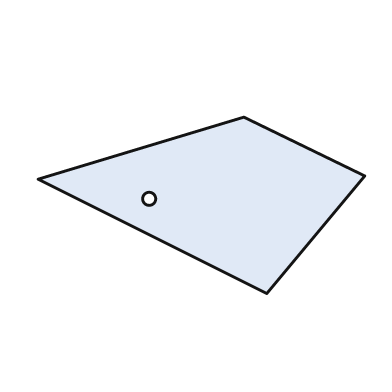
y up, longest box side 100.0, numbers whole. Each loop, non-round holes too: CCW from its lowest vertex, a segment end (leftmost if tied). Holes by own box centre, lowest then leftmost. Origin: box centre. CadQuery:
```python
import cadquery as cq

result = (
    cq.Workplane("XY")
    .moveTo(20.0, -27.0)
    .lineTo(50.0, 9.0)
    .lineTo(13.0, 27.0)
    .lineTo(-50.0, 8.0)
    .close()
    .moveTo(-16.0, 2.0)
    .circle(2.0)
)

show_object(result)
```